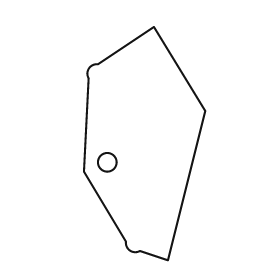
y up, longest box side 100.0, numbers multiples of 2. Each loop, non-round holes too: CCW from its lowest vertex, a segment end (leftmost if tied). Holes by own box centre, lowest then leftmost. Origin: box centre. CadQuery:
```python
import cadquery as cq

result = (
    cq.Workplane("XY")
    .moveTo(10.0, -50.0)
    .lineTo(26.0, 14.0)
    .lineTo(4.0, 50.0)
    .lineTo(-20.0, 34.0)
    .threePointArc((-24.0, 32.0), (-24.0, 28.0))
    .lineTo(-26.0, -12.0)
    .lineTo(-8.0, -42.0)
    .threePointArc((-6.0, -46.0), (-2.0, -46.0))
    .close()
    .moveTo(-16.0, -8.0)
    .circle(4.0)
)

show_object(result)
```